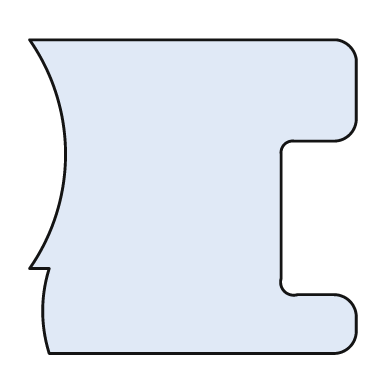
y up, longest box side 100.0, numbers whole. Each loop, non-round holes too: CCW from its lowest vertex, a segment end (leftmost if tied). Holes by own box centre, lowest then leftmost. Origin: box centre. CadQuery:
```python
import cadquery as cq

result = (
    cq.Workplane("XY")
    .moveTo(-44.0, -48.0)
    .lineTo(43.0, -48.0)
    .threePointArc((48.0, -46.0), (50.0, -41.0))
    .lineTo(50.0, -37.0)
    .threePointArc((48.0, -32.0), (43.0, -30.0))
    .lineTo(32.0, -30.0)
    .threePointArc((28.0, -29.0), (27.0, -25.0))
    .lineTo(27.0, 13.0)
    .threePointArc((28.0, 16.0), (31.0, 17.0))
    .lineTo(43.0, 17.0)
    .threePointArc((48.0, 19.0), (50.0, 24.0))
    .lineTo(50.0, 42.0)
    .threePointArc((48.0, 46.0), (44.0, 48.0))
    .lineTo(-50.0, 48.0)
    .threePointArc((-39.0, 13.0), (-50.0, -22.0))
    .lineTo(-44.0, -22.0)
    .threePointArc((-46.0, -35.0), (-44.0, -48.0))
    .close()
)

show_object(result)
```